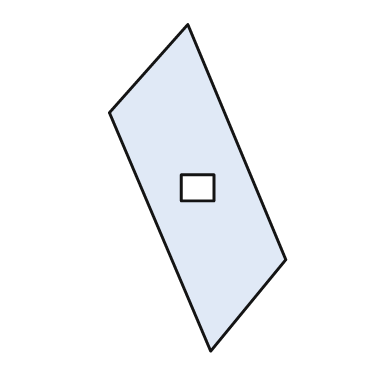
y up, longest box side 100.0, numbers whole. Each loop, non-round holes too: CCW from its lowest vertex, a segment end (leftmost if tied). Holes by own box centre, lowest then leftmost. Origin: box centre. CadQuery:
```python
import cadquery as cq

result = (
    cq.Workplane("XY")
    .moveTo(4.0, -50.0)
    .lineTo(27.0, -22.0)
    .lineTo(-3.0, 50.0)
    .lineTo(-27.0, 23.0)
    .close()
    .moveTo(-5.0, -4.0)
    .lineTo(5.0, -4.0)
    .lineTo(5.0, 4.0)
    .lineTo(-5.0, 4.0)
    .close()
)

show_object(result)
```